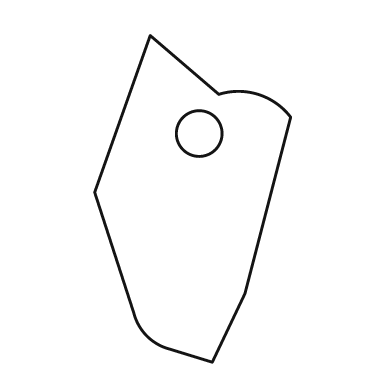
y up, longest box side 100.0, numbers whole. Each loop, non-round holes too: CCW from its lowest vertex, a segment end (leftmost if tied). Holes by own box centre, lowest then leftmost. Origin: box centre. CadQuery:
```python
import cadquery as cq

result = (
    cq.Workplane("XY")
    .moveTo(6.0, -50.0)
    .lineTo(16.0, -29.0)
    .lineTo(30.0, 25.0)
    .threePointArc((20.0, 32.0), (8.0, 32.0))
    .lineTo(-13.0, 50.0)
    .lineTo(-30.0, 2.0)
    .lineTo(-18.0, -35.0)
    .threePointArc((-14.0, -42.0), (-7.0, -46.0))
    .close()
    .moveTo(2.0, 20.0)
    .circle(7.0)
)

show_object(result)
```